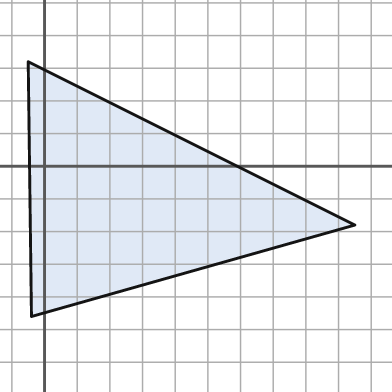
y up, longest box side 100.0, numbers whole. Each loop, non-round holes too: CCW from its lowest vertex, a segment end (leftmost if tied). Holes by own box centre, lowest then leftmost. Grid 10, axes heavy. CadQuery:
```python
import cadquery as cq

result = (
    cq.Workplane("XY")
    .moveTo(-4.0, -46.0)
    .lineTo(95.0, -18.0)
    .lineTo(-5.0, 32.0)
    .close()
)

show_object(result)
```